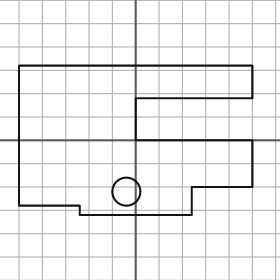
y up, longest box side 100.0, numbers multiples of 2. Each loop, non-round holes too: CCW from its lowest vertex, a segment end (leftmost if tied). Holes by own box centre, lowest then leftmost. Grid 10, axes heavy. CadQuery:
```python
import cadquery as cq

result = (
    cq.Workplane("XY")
    .moveTo(-24.0, -32.0)
    .lineTo(24.0, -32.0)
    .lineTo(24.0, -20.0)
    .lineTo(50.0, -20.0)
    .lineTo(50.0, 0.0)
    .lineTo(0.0, 0.0)
    .lineTo(0.0, 18.0)
    .lineTo(50.0, 18.0)
    .lineTo(50.0, 32.0)
    .lineTo(-50.0, 32.0)
    .lineTo(-50.0, -28.0)
    .lineTo(-24.0, -28.0)
    .close()
    .moveTo(-4.0, -22.0)
    .circle(6.0)
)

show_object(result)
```